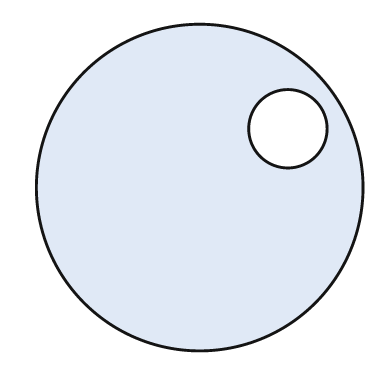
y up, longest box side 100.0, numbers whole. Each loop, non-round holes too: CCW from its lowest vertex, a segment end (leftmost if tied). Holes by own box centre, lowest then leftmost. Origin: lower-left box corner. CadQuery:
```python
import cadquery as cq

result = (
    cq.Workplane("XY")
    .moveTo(50.0, 50.0)
    .circle(50.0)
    .moveTo(77.0, 68.0)
    .circle(12.0)
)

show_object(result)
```